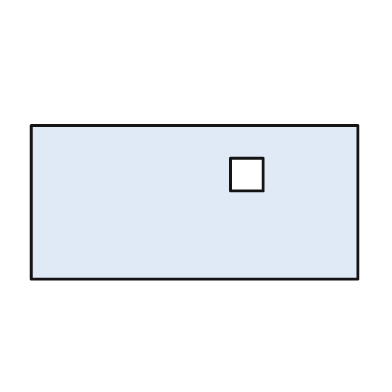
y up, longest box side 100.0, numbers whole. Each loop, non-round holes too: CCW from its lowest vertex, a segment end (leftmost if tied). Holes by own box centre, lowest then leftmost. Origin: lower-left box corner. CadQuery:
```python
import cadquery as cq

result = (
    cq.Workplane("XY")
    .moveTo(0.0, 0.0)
    .lineTo(100.0, 0.0)
    .lineTo(100.0, 47.0)
    .lineTo(0.0, 47.0)
    .close()
    .moveTo(61.0, 27.0)
    .lineTo(71.0, 27.0)
    .lineTo(71.0, 37.0)
    .lineTo(61.0, 37.0)
    .close()
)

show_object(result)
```